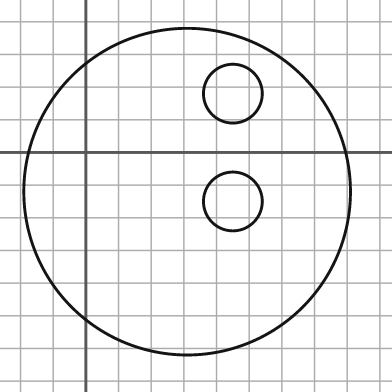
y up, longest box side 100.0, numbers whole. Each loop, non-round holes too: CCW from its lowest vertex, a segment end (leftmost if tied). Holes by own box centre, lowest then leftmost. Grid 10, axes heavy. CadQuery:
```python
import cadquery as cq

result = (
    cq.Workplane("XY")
    .moveTo(31.0, -12.0)
    .circle(50.0)
    .moveTo(45.0, -15.0)
    .circle(9.0)
    .moveTo(45.0, 18.0)
    .circle(9.0)
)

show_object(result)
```